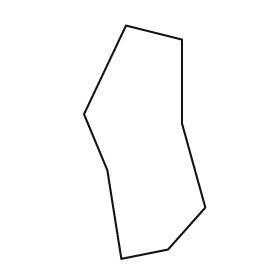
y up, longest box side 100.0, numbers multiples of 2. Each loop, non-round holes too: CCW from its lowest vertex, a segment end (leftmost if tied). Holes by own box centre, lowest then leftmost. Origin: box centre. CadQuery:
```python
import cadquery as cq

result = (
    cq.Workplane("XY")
    .moveTo(-10.0, -50.0)
    .lineTo(10.0, -46.0)
    .lineTo(26.0, -28.0)
    .lineTo(16.0, 8.0)
    .lineTo(16.0, 44.0)
    .lineTo(-8.0, 50.0)
    .lineTo(-26.0, 12.0)
    .lineTo(-16.0, -12.0)
    .close()
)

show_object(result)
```